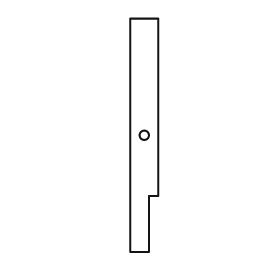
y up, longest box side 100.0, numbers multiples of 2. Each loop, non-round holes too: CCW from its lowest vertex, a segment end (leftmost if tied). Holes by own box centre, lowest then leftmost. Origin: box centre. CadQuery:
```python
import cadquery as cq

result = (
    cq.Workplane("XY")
    .moveTo(-6.0, -50.0)
    .lineTo(2.0, -50.0)
    .lineTo(2.0, -26.0)
    .lineTo(6.0, -26.0)
    .lineTo(6.0, 50.0)
    .lineTo(-6.0, 50.0)
    .close()
    .moveTo(0.0, 0.0)
    .circle(2.0)
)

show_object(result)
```